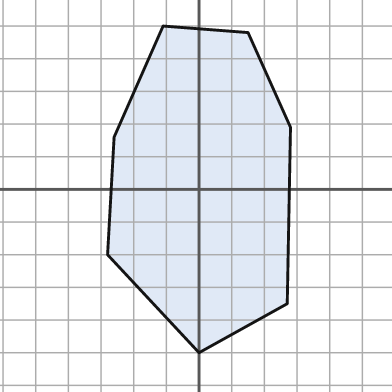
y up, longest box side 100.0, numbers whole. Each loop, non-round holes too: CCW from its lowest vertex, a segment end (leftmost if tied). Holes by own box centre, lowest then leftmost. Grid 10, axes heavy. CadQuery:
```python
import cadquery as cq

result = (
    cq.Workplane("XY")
    .moveTo(0.0, -50.0)
    .lineTo(27.0, -35.0)
    .lineTo(28.0, 19.0)
    .lineTo(15.0, 48.0)
    .lineTo(-11.0, 50.0)
    .lineTo(-26.0, 16.0)
    .lineTo(-28.0, -20.0)
    .close()
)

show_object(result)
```